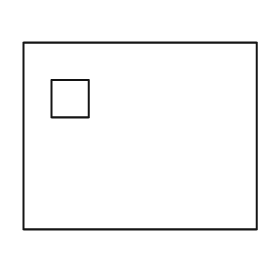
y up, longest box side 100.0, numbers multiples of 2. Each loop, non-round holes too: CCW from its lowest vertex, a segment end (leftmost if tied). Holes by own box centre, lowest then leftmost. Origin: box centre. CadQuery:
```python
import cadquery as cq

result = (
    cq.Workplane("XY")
    .moveTo(-50.0, -40.0)
    .lineTo(50.0, -40.0)
    .lineTo(50.0, 40.0)
    .lineTo(-50.0, 40.0)
    .close()
    .moveTo(-38.0, 8.0)
    .lineTo(-22.0, 8.0)
    .lineTo(-22.0, 24.0)
    .lineTo(-38.0, 24.0)
    .close()
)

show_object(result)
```